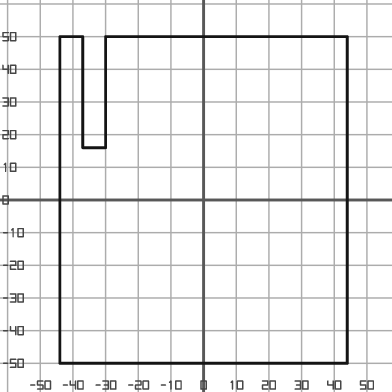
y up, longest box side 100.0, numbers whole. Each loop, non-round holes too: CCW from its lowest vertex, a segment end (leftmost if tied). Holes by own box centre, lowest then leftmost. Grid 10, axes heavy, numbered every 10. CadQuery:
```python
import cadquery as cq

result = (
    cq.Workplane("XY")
    .moveTo(-44.0, -50.0)
    .lineTo(44.0, -50.0)
    .lineTo(44.0, 50.0)
    .lineTo(-30.0, 50.0)
    .lineTo(-30.0, 16.0)
    .lineTo(-37.0, 16.0)
    .lineTo(-37.0, 50.0)
    .lineTo(-44.0, 50.0)
    .close()
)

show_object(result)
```